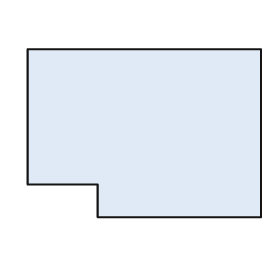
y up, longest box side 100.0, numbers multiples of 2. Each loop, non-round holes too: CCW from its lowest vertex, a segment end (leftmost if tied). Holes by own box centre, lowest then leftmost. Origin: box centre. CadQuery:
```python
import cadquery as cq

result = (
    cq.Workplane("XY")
    .moveTo(-20.0, -36.0)
    .lineTo(50.0, -36.0)
    .lineTo(50.0, 36.0)
    .lineTo(-50.0, 36.0)
    .lineTo(-50.0, -22.0)
    .lineTo(-20.0, -22.0)
    .close()
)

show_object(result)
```